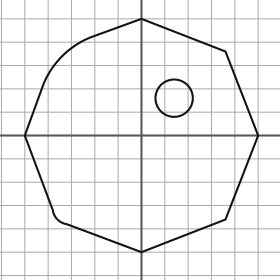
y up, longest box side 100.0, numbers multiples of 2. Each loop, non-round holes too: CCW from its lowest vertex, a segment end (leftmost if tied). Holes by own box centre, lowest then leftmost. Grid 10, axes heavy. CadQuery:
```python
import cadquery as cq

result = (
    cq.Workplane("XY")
    .moveTo(0.0, -50.0)
    .lineTo(36.0, -36.0)
    .lineTo(50.0, 0.0)
    .lineTo(36.0, 36.0)
    .lineTo(0.0, 50.0)
    .lineTo(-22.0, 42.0)
    .threePointArc((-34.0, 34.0), (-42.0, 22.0))
    .lineTo(-50.0, 0.0)
    .lineTo(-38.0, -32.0)
    .threePointArc((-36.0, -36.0), (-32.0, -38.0))
    .close()
    .moveTo(14.0, 16.0)
    .circle(8.0)
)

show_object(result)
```